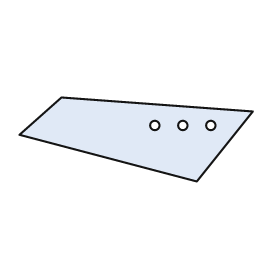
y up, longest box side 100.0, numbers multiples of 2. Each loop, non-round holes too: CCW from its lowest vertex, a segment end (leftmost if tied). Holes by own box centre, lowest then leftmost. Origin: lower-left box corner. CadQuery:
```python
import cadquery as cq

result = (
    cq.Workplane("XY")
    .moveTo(76.0, 0.0)
    .lineTo(100.0, 30.0)
    .lineTo(18.0, 36.0)
    .lineTo(0.0, 20.0)
    .close()
    .moveTo(58.0, 24.0)
    .circle(2.0)
    .moveTo(70.0, 24.0)
    .circle(2.0)
    .moveTo(82.0, 24.0)
    .circle(2.0)
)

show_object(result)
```